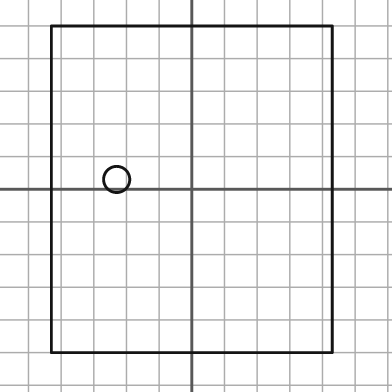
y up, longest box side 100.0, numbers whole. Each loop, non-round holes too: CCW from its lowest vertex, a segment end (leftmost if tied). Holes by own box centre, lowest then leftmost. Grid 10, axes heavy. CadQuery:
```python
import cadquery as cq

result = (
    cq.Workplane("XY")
    .moveTo(-43.0, -50.0)
    .lineTo(43.0, -50.0)
    .lineTo(43.0, 50.0)
    .lineTo(-43.0, 50.0)
    .close()
    .moveTo(-23.0, 3.0)
    .circle(4.0)
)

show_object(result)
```